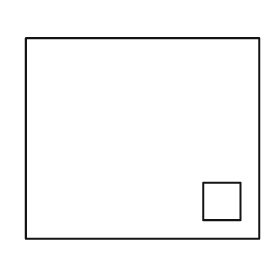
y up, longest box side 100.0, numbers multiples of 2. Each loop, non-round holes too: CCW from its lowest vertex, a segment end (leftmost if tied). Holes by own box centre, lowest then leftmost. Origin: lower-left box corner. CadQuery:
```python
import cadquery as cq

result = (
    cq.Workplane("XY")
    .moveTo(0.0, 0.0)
    .lineTo(100.0, 0.0)
    .lineTo(100.0, 86.0)
    .lineTo(0.0, 86.0)
    .close()
    .moveTo(76.0, 8.0)
    .lineTo(92.0, 8.0)
    .lineTo(92.0, 24.0)
    .lineTo(76.0, 24.0)
    .close()
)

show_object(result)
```